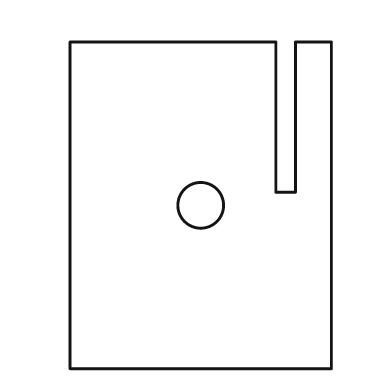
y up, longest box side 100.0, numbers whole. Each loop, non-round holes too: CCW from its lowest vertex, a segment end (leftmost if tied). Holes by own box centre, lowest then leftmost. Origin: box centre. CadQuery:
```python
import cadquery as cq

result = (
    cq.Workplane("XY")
    .moveTo(-40.0, -50.0)
    .lineTo(40.0, -50.0)
    .lineTo(40.0, 50.0)
    .lineTo(29.0, 50.0)
    .lineTo(29.0, 4.0)
    .lineTo(23.0, 4.0)
    .lineTo(23.0, 50.0)
    .lineTo(-40.0, 50.0)
    .close()
    .moveTo(0.0, 0.0)
    .circle(7.0)
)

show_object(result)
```